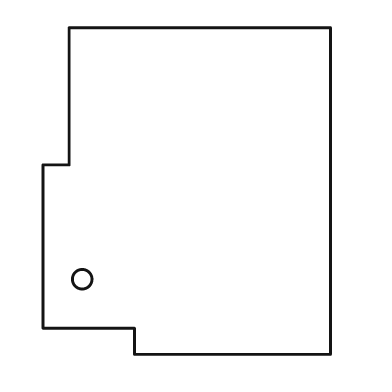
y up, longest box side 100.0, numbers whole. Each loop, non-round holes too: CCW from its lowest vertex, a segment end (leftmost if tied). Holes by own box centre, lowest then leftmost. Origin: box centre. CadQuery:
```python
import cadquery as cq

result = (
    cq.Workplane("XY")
    .moveTo(-16.0, -50.0)
    .lineTo(44.0, -50.0)
    .lineTo(44.0, 50.0)
    .lineTo(-36.0, 50.0)
    .lineTo(-36.0, 8.0)
    .lineTo(-44.0, 8.0)
    .lineTo(-44.0, -42.0)
    .lineTo(-16.0, -42.0)
    .close()
    .moveTo(-32.0, -27.0)
    .circle(3.0)
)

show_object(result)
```